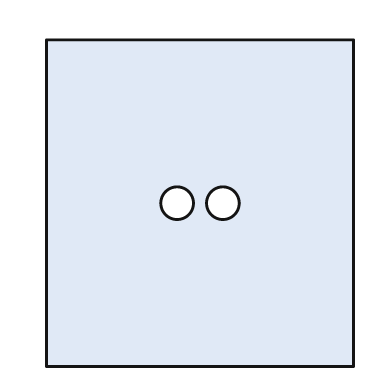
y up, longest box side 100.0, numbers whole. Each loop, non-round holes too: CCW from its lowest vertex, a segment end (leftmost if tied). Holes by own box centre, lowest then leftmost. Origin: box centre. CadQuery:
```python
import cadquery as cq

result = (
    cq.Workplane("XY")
    .moveTo(-47.0, -50.0)
    .lineTo(47.0, -50.0)
    .lineTo(47.0, 50.0)
    .lineTo(-47.0, 50.0)
    .close()
    .moveTo(-7.0, 0.0)
    .circle(5.0)
    .moveTo(7.0, 0.0)
    .circle(5.0)
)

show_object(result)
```